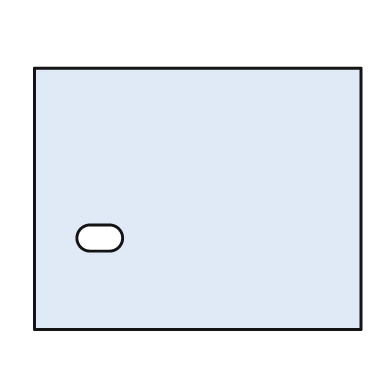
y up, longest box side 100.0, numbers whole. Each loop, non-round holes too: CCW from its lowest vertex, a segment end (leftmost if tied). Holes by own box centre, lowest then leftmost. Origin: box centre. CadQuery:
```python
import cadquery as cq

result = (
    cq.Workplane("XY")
    .moveTo(-50.0, -40.0)
    .lineTo(50.0, -40.0)
    .lineTo(50.0, 40.0)
    .lineTo(-50.0, 40.0)
    .close()
    .moveTo(-33.0, -16.0)
    .lineTo(-27.0, -16.0)
    .threePointArc((-23.0, -12.0), (-27.0, -8.0))
    .lineTo(-33.0, -8.0)
    .threePointArc((-37.0, -12.0), (-33.0, -16.0))
    .close()
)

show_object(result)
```